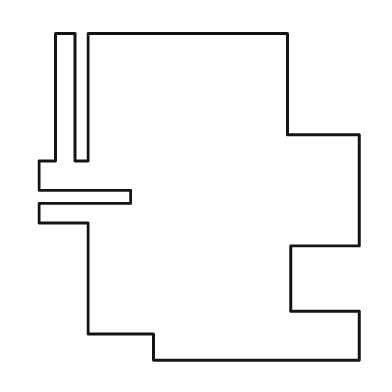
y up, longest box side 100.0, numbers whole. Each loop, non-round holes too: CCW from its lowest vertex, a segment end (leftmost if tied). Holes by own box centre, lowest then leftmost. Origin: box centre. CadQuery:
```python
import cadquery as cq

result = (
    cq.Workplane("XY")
    .moveTo(-14.0, -50.0)
    .lineTo(49.0, -50.0)
    .lineTo(49.0, -35.0)
    .lineTo(28.0, -35.0)
    .lineTo(28.0, -15.0)
    .lineTo(49.0, -15.0)
    .lineTo(49.0, 19.0)
    .lineTo(27.0, 19.0)
    .lineTo(27.0, 50.0)
    .lineTo(-34.0, 50.0)
    .lineTo(-34.0, 11.0)
    .lineTo(-38.0, 11.0)
    .lineTo(-38.0, 50.0)
    .lineTo(-44.0, 50.0)
    .lineTo(-44.0, 11.0)
    .lineTo(-49.0, 11.0)
    .lineTo(-49.0, 2.0)
    .lineTo(-21.0, 2.0)
    .lineTo(-21.0, -2.0)
    .lineTo(-49.0, -2.0)
    .lineTo(-49.0, -8.0)
    .lineTo(-34.0, -8.0)
    .lineTo(-34.0, -42.0)
    .lineTo(-14.0, -42.0)
    .close()
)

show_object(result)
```